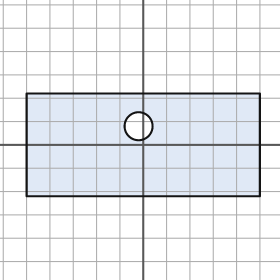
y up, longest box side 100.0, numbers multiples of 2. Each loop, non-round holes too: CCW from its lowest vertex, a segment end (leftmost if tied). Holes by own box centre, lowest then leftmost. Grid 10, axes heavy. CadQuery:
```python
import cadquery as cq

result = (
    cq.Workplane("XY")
    .moveTo(-50.0, -22.0)
    .lineTo(50.0, -22.0)
    .lineTo(50.0, 22.0)
    .lineTo(-50.0, 22.0)
    .close()
    .moveTo(-2.0, 8.0)
    .circle(6.0)
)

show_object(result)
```